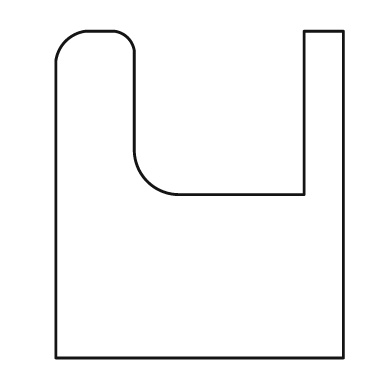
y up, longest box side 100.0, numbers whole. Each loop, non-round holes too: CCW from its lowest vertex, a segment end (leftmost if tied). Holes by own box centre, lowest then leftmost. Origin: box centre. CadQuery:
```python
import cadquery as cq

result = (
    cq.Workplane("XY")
    .moveTo(-44.0, -50.0)
    .lineTo(44.0, -50.0)
    .lineTo(44.0, 50.0)
    .lineTo(32.0, 50.0)
    .lineTo(32.0, 0.0)
    .lineTo(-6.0, 0.0)
    .threePointArc((-16.0, 4.0), (-20.0, 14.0))
    .lineTo(-20.0, 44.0)
    .threePointArc((-22.0, 48.0), (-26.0, 50.0))
    .lineTo(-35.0, 50.0)
    .threePointArc((-41.0, 47.0), (-44.0, 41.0))
    .close()
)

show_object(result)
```